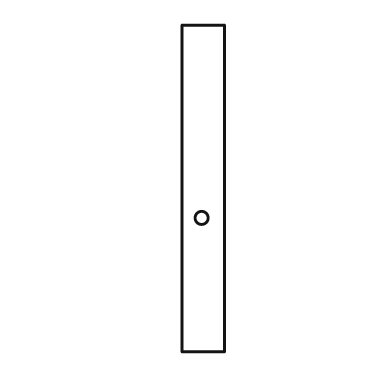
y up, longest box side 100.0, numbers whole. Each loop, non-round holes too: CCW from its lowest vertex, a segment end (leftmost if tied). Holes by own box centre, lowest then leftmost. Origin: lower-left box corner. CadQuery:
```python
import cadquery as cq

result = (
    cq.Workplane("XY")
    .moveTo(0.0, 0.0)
    .lineTo(13.0, 0.0)
    .lineTo(13.0, 100.0)
    .lineTo(0.0, 100.0)
    .close()
    .moveTo(6.0, 41.0)
    .circle(2.0)
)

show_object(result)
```